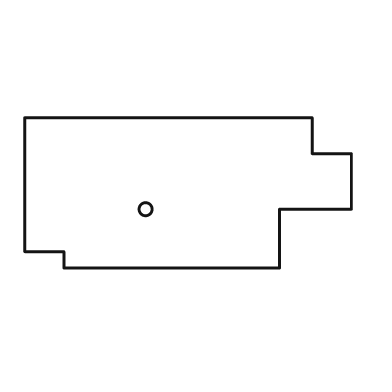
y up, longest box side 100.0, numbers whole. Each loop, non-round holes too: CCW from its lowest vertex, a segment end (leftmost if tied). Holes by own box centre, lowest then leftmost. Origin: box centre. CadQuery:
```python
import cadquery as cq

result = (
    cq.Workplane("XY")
    .moveTo(-38.0, -23.0)
    .lineTo(28.0, -23.0)
    .lineTo(28.0, -5.0)
    .lineTo(50.0, -5.0)
    .lineTo(50.0, 12.0)
    .lineTo(38.0, 12.0)
    .lineTo(38.0, 23.0)
    .lineTo(-50.0, 23.0)
    .lineTo(-50.0, -18.0)
    .lineTo(-38.0, -18.0)
    .close()
    .moveTo(-13.0, -5.0)
    .circle(2.0)
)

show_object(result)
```